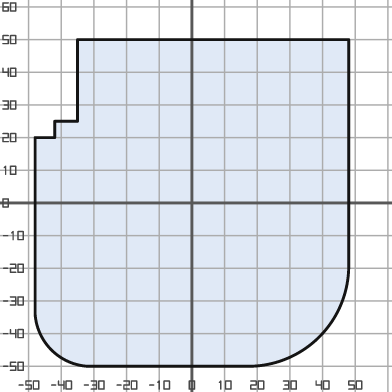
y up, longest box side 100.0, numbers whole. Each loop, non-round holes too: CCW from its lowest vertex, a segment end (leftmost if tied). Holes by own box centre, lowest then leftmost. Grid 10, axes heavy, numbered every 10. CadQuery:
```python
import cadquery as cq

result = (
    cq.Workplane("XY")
    .moveTo(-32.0, -50.0)
    .lineTo(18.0, -50.0)
    .threePointArc((39.0, -41.0), (48.0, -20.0))
    .lineTo(48.0, 50.0)
    .lineTo(-35.0, 50.0)
    .lineTo(-35.0, 25.0)
    .lineTo(-42.0, 25.0)
    .lineTo(-42.0, 20.0)
    .lineTo(-48.0, 20.0)
    .lineTo(-48.0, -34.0)
    .threePointArc((-43.0, -45.0), (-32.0, -50.0))
    .close()
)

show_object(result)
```